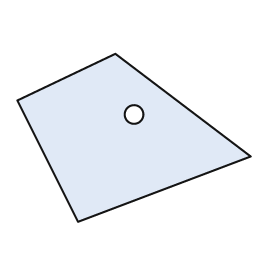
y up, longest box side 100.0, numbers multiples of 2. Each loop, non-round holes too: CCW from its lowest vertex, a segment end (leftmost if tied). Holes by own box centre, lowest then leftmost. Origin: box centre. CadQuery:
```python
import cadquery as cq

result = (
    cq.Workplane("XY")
    .moveTo(-24.0, -36.0)
    .lineTo(50.0, -8.0)
    .lineTo(-8.0, 36.0)
    .lineTo(-50.0, 16.0)
    .close()
    .moveTo(0.0, 10.0)
    .circle(4.0)
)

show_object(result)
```